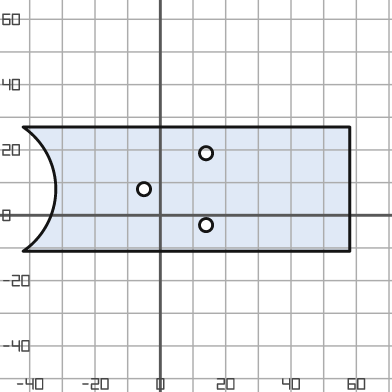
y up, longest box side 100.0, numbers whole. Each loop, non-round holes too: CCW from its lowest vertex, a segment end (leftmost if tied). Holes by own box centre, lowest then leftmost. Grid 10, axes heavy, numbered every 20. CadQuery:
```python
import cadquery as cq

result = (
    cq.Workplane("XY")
    .moveTo(-42.0, -11.0)
    .lineTo(58.0, -11.0)
    .lineTo(58.0, 27.0)
    .lineTo(-42.0, 27.0)
    .threePointArc((-32.0, 8.0), (-42.0, -11.0))
    .close()
    .moveTo(14.0, -3.0)
    .circle(2.0)
    .moveTo(-5.0, 8.0)
    .circle(2.0)
    .moveTo(14.0, 19.0)
    .circle(2.0)
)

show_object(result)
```